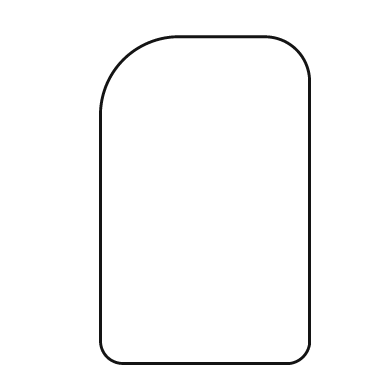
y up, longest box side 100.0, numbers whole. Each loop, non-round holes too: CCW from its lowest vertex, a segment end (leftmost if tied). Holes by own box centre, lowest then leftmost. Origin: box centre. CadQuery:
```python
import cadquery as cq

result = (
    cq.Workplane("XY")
    .moveTo(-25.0, -50.0)
    .lineTo(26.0, -50.0)
    .threePointArc((30.0, -48.0), (32.0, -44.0))
    .lineTo(32.0, 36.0)
    .threePointArc((28.0, 46.0), (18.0, 50.0))
    .lineTo(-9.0, 50.0)
    .threePointArc((-25.0, 43.0), (-32.0, 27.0))
    .lineTo(-32.0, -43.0)
    .threePointArc((-30.0, -48.0), (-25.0, -50.0))
    .close()
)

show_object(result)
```